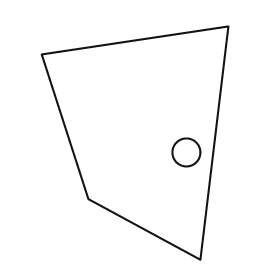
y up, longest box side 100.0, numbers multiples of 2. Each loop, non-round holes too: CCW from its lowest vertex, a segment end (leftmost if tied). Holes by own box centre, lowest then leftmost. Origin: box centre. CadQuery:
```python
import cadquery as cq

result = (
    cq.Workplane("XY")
    .moveTo(28.0, -50.0)
    .lineTo(40.0, 50.0)
    .lineTo(-40.0, 38.0)
    .lineTo(-20.0, -24.0)
    .close()
    .moveTo(22.0, -4.0)
    .circle(6.0)
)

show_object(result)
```